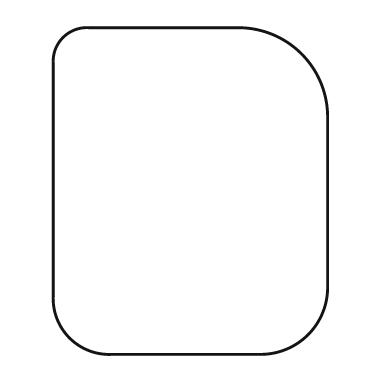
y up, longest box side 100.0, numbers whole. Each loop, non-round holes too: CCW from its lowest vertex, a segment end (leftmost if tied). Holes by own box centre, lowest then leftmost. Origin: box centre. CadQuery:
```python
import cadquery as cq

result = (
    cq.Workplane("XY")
    .moveTo(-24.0, -50.0)
    .lineTo(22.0, -50.0)
    .threePointArc((36.0, -44.0), (42.0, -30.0))
    .lineTo(42.0, 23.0)
    .threePointArc((34.0, 42.0), (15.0, 50.0))
    .lineTo(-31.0, 50.0)
    .threePointArc((-39.0, 47.0), (-42.0, 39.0))
    .lineTo(-42.0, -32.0)
    .threePointArc((-37.0, -45.0), (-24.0, -50.0))
    .close()
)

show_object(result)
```